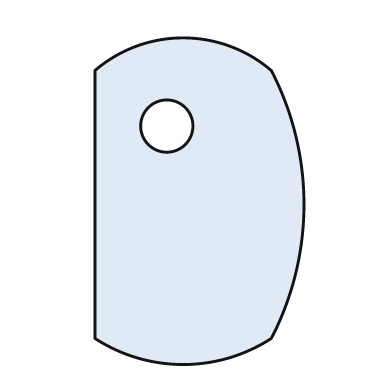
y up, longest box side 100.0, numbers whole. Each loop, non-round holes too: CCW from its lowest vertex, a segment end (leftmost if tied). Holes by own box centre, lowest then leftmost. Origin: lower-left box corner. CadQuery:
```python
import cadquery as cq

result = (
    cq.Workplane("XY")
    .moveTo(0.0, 8.0)
    .threePointArc((27.0, 0.0), (54.0, 8.0))
    .threePointArc((64.0, 49.0), (54.0, 90.0))
    .threePointArc((27.0, 100.0), (0.0, 90.0))
    .close()
    .moveTo(22.0, 73.0)
    .circle(8.0)
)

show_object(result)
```